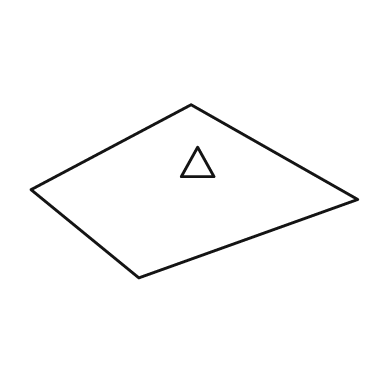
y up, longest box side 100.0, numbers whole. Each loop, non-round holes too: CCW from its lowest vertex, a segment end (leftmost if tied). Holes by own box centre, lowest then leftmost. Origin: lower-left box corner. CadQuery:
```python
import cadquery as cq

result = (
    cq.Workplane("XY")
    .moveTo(33.0, 0.0)
    .lineTo(100.0, 24.0)
    .lineTo(49.0, 53.0)
    .lineTo(0.0, 27.0)
    .close()
    .moveTo(46.0, 31.0)
    .lineTo(56.0, 31.0)
    .lineTo(51.0, 40.0)
    .close()
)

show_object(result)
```